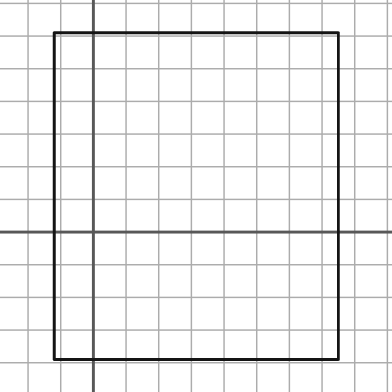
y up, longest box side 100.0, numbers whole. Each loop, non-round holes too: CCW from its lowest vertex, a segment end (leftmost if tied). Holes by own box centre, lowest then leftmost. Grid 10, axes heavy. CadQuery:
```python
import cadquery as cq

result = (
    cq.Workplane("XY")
    .moveTo(-12.0, -39.0)
    .lineTo(75.0, -39.0)
    .lineTo(75.0, 61.0)
    .lineTo(-12.0, 61.0)
    .close()
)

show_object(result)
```